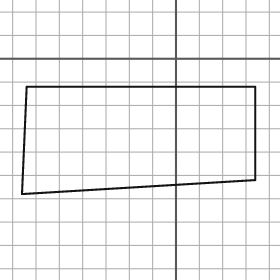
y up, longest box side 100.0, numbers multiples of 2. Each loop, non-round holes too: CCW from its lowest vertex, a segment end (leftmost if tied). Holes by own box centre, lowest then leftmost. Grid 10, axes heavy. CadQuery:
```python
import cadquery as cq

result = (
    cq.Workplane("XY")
    .moveTo(-66.0, -58.0)
    .lineTo(34.0, -52.0)
    .lineTo(34.0, -12.0)
    .lineTo(-64.0, -12.0)
    .close()
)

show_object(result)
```